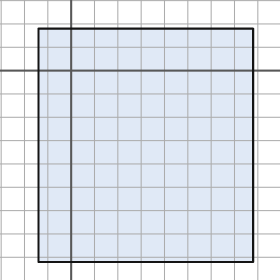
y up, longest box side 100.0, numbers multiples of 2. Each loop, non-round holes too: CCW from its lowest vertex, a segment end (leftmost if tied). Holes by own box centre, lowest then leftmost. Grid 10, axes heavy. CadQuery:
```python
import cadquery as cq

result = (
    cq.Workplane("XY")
    .moveTo(-14.0, -82.0)
    .lineTo(78.0, -82.0)
    .lineTo(78.0, 18.0)
    .lineTo(-14.0, 18.0)
    .close()
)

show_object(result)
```